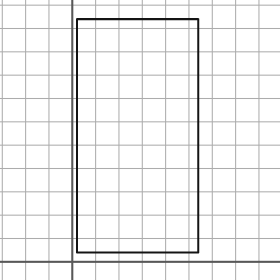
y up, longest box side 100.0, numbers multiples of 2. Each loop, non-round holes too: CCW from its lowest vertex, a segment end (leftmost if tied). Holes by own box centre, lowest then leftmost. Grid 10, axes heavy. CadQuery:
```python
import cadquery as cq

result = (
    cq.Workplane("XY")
    .moveTo(2.0, 4.0)
    .lineTo(54.0, 4.0)
    .lineTo(54.0, 104.0)
    .lineTo(2.0, 104.0)
    .close()
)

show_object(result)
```